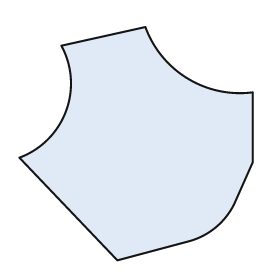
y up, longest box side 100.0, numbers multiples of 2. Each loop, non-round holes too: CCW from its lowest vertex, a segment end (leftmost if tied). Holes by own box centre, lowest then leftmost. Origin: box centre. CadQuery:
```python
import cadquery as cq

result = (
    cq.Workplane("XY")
    .moveTo(-8.0, -50.0)
    .lineTo(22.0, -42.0)
    .threePointArc((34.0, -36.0), (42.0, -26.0))
    .lineTo(50.0, -8.0)
    .lineTo(50.0, 22.0)
    .threePointArc((22.0, 28.0), (4.0, 50.0))
    .lineTo(-32.0, 42.0)
    .threePointArc((-30.0, 14.0), (-50.0, -6.0))
    .close()
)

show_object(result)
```